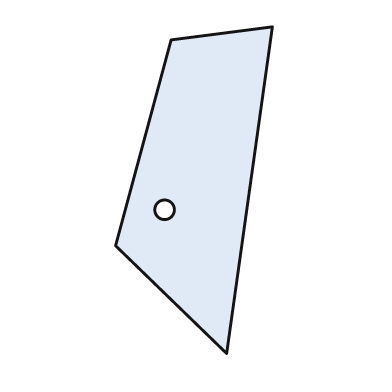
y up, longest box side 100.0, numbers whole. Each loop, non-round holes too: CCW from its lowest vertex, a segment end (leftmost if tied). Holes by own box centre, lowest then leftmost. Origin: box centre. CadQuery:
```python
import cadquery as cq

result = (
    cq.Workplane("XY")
    .moveTo(10.0, -50.0)
    .lineTo(24.0, 50.0)
    .lineTo(-7.0, 46.0)
    .lineTo(-24.0, -17.0)
    .close()
    .moveTo(-9.0, -6.0)
    .circle(3.0)
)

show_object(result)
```